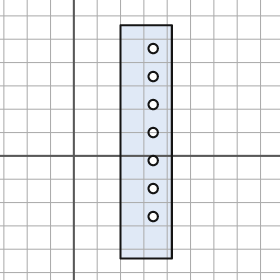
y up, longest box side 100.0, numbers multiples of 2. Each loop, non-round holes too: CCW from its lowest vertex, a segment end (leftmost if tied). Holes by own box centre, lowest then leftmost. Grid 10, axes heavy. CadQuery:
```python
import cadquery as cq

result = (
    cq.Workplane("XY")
    .moveTo(20.0, -44.0)
    .lineTo(42.0, -44.0)
    .lineTo(42.0, 56.0)
    .lineTo(20.0, 56.0)
    .close()
    .moveTo(34.0, -26.0)
    .circle(2.0)
    .moveTo(34.0, -14.0)
    .circle(2.0)
    .moveTo(34.0, -2.0)
    .circle(2.0)
    .moveTo(34.0, 10.0)
    .circle(2.0)
    .moveTo(34.0, 22.0)
    .circle(2.0)
    .moveTo(34.0, 34.0)
    .circle(2.0)
    .moveTo(34.0, 46.0)
    .circle(2.0)
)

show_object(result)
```